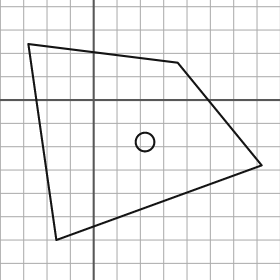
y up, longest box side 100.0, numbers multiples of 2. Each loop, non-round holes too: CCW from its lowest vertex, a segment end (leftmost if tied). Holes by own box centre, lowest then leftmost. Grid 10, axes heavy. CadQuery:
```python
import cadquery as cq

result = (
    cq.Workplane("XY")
    .moveTo(-16.0, -60.0)
    .lineTo(72.0, -28.0)
    .lineTo(36.0, 16.0)
    .lineTo(-28.0, 24.0)
    .close()
    .moveTo(22.0, -18.0)
    .circle(4.0)
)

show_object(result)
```